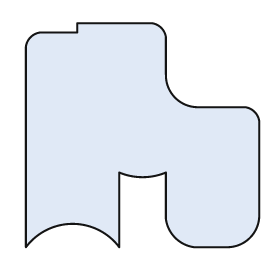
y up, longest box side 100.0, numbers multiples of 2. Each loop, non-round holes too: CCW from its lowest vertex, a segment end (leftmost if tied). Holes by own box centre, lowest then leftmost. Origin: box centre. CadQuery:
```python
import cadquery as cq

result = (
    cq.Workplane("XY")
    .moveTo(-50.0, -48.0)
    .threePointArc((-30.0, -38.0), (-10.0, -48.0))
    .lineTo(-10.0, -16.0)
    .threePointArc((0.0, -18.0), (10.0, -16.0))
    .lineTo(10.0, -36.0)
    .threePointArc((14.0, -44.0), (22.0, -48.0))
    .lineTo(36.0, -48.0)
    .threePointArc((46.0, -44.0), (50.0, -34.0))
    .lineTo(50.0, 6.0)
    .threePointArc((48.0, 10.0), (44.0, 12.0))
    .lineTo(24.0, 12.0)
    .threePointArc((14.0, 16.0), (10.0, 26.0))
    .lineTo(10.0, 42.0)
    .threePointArc((8.0, 46.0), (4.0, 48.0))
    .lineTo(-28.0, 48.0)
    .lineTo(-28.0, 44.0)
    .lineTo(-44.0, 44.0)
    .threePointArc((-48.0, 42.0), (-50.0, 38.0))
    .close()
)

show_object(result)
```